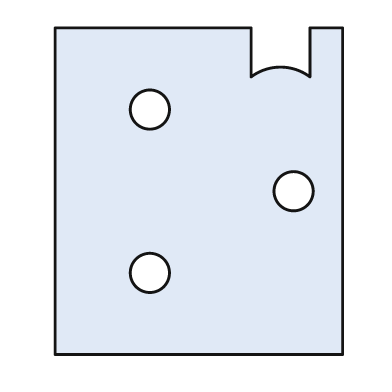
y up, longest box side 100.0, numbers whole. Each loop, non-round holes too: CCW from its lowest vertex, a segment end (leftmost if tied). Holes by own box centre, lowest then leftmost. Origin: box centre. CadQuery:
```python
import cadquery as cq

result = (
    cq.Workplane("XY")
    .moveTo(-44.0, -50.0)
    .lineTo(44.0, -50.0)
    .lineTo(44.0, 50.0)
    .lineTo(34.0, 50.0)
    .lineTo(34.0, 35.0)
    .threePointArc((25.0, 38.0), (16.0, 35.0))
    .lineTo(16.0, 50.0)
    .lineTo(-44.0, 50.0)
    .close()
    .moveTo(-15.0, -25.0)
    .circle(6.0)
    .moveTo(29.0, 0.0)
    .circle(6.0)
    .moveTo(-15.0, 25.0)
    .circle(6.0)
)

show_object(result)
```